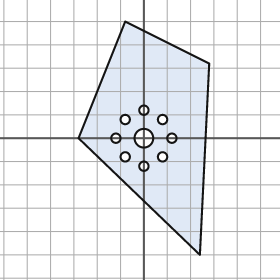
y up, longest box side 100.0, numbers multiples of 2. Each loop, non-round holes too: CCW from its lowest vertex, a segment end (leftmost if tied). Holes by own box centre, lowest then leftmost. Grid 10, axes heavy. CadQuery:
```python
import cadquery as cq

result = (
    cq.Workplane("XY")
    .moveTo(24.0, -50.0)
    .lineTo(28.0, 32.0)
    .lineTo(-8.0, 50.0)
    .lineTo(-28.0, 0.0)
    .close()
    .moveTo(0.0, -12.0)
    .circle(2.0)
    .moveTo(-8.0, -8.0)
    .circle(2.0)
    .moveTo(8.0, -8.0)
    .circle(2.0)
    .moveTo(-12.0, 0.0)
    .circle(2.0)
    .moveTo(0.0, 0.0)
    .circle(4.0)
    .moveTo(12.0, 0.0)
    .circle(2.0)
    .moveTo(-8.0, 8.0)
    .circle(2.0)
    .moveTo(8.0, 8.0)
    .circle(2.0)
    .moveTo(0.0, 12.0)
    .circle(2.0)
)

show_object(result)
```